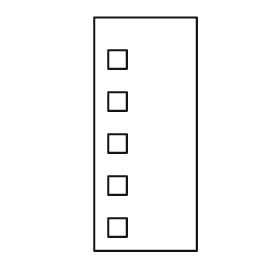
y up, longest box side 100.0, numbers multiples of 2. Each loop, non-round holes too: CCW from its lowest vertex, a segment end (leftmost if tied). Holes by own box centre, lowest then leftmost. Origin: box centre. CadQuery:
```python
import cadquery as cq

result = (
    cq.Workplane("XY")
    .moveTo(-22.0, -50.0)
    .lineTo(22.0, -50.0)
    .lineTo(22.0, 50.0)
    .lineTo(-22.0, 50.0)
    .close()
    .moveTo(-16.0, -44.0)
    .lineTo(-8.0, -44.0)
    .lineTo(-8.0, -36.0)
    .lineTo(-16.0, -36.0)
    .close()
    .moveTo(-16.0, -26.0)
    .lineTo(-8.0, -26.0)
    .lineTo(-8.0, -18.0)
    .lineTo(-16.0, -18.0)
    .close()
    .moveTo(-16.0, -8.0)
    .lineTo(-8.0, -8.0)
    .lineTo(-8.0, 0.0)
    .lineTo(-16.0, 0.0)
    .close()
    .moveTo(-16.0, 10.0)
    .lineTo(-8.0, 10.0)
    .lineTo(-8.0, 18.0)
    .lineTo(-16.0, 18.0)
    .close()
    .moveTo(-16.0, 28.0)
    .lineTo(-8.0, 28.0)
    .lineTo(-8.0, 36.0)
    .lineTo(-16.0, 36.0)
    .close()
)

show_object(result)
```